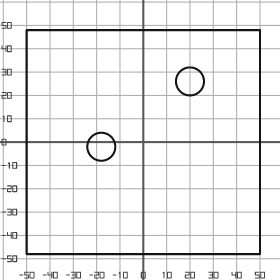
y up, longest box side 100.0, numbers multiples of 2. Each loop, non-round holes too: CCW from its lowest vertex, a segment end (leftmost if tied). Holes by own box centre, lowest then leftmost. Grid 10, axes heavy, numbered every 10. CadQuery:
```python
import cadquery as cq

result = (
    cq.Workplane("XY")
    .moveTo(-50.0, -48.0)
    .lineTo(50.0, -48.0)
    .lineTo(50.0, 48.0)
    .lineTo(-50.0, 48.0)
    .close()
    .moveTo(-18.0, -2.0)
    .circle(6.0)
    .moveTo(20.0, 26.0)
    .circle(6.0)
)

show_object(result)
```